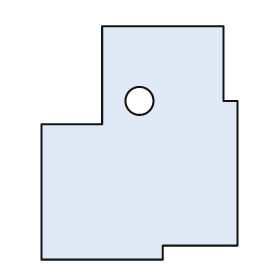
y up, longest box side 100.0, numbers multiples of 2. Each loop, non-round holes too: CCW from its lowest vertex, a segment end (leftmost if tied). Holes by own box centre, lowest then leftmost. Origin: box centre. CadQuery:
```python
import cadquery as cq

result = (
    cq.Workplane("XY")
    .moveTo(-42.0, -50.0)
    .lineTo(10.0, -50.0)
    .lineTo(10.0, -44.0)
    .lineTo(42.0, -44.0)
    .lineTo(42.0, 18.0)
    .lineTo(36.0, 18.0)
    .lineTo(36.0, 50.0)
    .lineTo(-16.0, 50.0)
    .lineTo(-16.0, 8.0)
    .lineTo(-42.0, 8.0)
    .close()
    .moveTo(0.0, 18.0)
    .circle(6.0)
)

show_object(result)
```